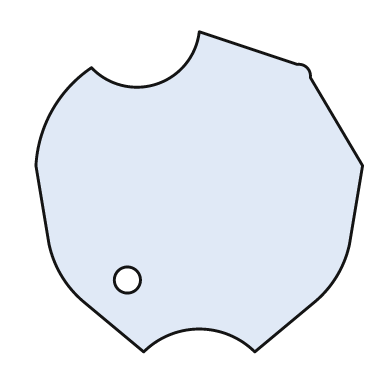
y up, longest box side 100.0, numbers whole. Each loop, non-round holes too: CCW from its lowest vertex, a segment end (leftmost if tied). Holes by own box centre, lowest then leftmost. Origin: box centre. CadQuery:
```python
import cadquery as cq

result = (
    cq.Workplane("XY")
    .moveTo(-17.0, -49.0)
    .threePointArc((0.0, -42.0), (17.0, -49.0))
    .lineTo(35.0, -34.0)
    .threePointArc((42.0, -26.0), (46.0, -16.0))
    .lineTo(50.0, 8.0)
    .lineTo(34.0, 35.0)
    .threePointArc((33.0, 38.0), (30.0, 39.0))
    .lineTo(0.0, 49.0)
    .threePointArc((-13.0, 33.0), (-33.0, 38.0))
    .threePointArc((-45.0, 25.0), (-50.0, 8.0))
    .lineTo(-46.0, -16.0)
    .threePointArc((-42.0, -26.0), (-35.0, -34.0))
    .close()
    .moveTo(-22.0, -27.0)
    .circle(4.0)
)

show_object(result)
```